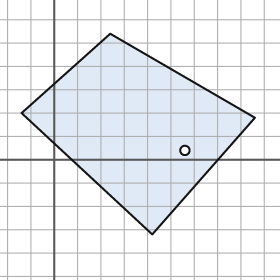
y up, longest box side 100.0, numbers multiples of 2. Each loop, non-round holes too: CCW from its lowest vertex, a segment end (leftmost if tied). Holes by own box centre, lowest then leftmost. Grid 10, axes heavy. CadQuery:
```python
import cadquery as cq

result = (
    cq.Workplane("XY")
    .moveTo(42.0, -32.0)
    .lineTo(86.0, 18.0)
    .lineTo(24.0, 54.0)
    .lineTo(-14.0, 20.0)
    .close()
    .moveTo(56.0, 4.0)
    .circle(2.0)
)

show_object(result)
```